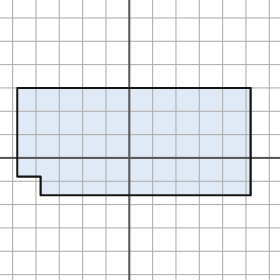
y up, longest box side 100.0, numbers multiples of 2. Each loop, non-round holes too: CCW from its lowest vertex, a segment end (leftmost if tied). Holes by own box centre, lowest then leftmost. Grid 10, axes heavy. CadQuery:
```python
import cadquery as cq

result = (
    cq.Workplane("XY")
    .moveTo(-38.0, -16.0)
    .lineTo(52.0, -16.0)
    .lineTo(52.0, 30.0)
    .lineTo(-48.0, 30.0)
    .lineTo(-48.0, -8.0)
    .lineTo(-38.0, -8.0)
    .close()
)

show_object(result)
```